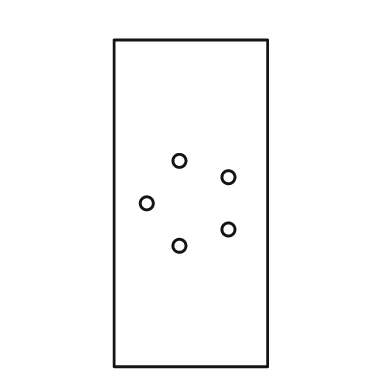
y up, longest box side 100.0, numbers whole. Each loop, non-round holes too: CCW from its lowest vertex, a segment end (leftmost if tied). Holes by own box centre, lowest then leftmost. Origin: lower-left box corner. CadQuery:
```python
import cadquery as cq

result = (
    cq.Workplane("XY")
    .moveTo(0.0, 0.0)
    .lineTo(47.0, 0.0)
    .lineTo(47.0, 100.0)
    .lineTo(0.0, 100.0)
    .close()
    .moveTo(20.0, 37.0)
    .circle(2.0)
    .moveTo(35.0, 42.0)
    .circle(2.0)
    .moveTo(10.0, 50.0)
    .circle(2.0)
    .moveTo(35.0, 58.0)
    .circle(2.0)
    .moveTo(20.0, 63.0)
    .circle(2.0)
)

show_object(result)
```